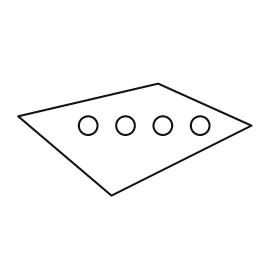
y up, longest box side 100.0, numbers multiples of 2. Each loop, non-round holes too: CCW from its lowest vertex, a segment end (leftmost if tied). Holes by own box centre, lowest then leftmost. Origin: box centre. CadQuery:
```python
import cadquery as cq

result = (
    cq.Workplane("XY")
    .moveTo(-10.0, -24.0)
    .lineTo(50.0, 6.0)
    .lineTo(10.0, 24.0)
    .lineTo(-50.0, 10.0)
    .close()
    .moveTo(-20.0, 6.0)
    .circle(4.0)
    .moveTo(-4.0, 6.0)
    .circle(4.0)
    .moveTo(12.0, 6.0)
    .circle(4.0)
    .moveTo(28.0, 6.0)
    .circle(4.0)
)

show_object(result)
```